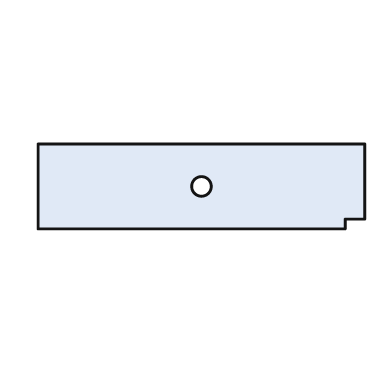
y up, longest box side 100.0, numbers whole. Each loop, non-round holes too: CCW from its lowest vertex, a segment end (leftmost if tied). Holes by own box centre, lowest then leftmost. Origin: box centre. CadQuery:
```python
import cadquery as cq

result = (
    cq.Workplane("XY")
    .moveTo(-50.0, -13.0)
    .lineTo(44.0, -13.0)
    .lineTo(44.0, -10.0)
    .lineTo(50.0, -10.0)
    .lineTo(50.0, 13.0)
    .lineTo(-50.0, 13.0)
    .close()
    .moveTo(0.0, 0.0)
    .circle(3.0)
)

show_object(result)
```